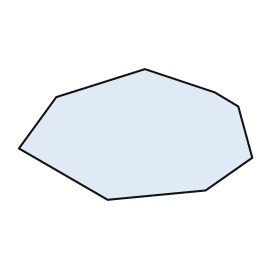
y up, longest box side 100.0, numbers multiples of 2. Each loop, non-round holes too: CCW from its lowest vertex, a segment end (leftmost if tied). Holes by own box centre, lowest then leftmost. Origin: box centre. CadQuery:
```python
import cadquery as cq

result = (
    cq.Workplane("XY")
    .moveTo(-12.0, -28.0)
    .lineTo(30.0, -24.0)
    .lineTo(50.0, -10.0)
    .lineTo(44.0, 12.0)
    .lineTo(34.0, 18.0)
    .lineTo(4.0, 28.0)
    .lineTo(-34.0, 16.0)
    .lineTo(-50.0, -6.0)
    .close()
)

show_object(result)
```